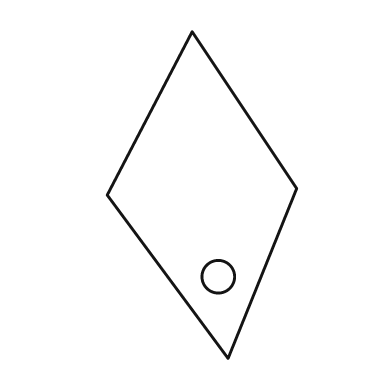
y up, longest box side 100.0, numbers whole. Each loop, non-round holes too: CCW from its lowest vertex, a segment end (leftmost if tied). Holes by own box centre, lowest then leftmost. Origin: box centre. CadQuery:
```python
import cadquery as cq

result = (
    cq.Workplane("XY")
    .moveTo(8.0, -50.0)
    .lineTo(29.0, 2.0)
    .lineTo(-3.0, 50.0)
    .lineTo(-29.0, 0.0)
    .close()
    .moveTo(5.0, -25.0)
    .circle(5.0)
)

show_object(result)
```